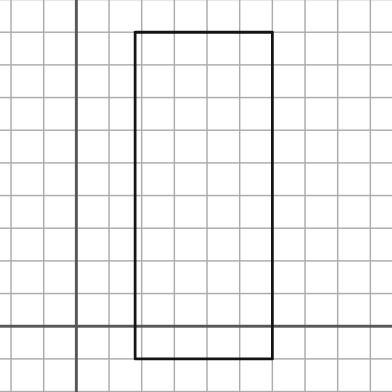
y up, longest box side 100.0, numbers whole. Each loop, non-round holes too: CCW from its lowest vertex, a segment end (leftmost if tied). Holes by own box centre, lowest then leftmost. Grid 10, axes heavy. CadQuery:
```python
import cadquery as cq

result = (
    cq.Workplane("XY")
    .moveTo(18.0, -10.0)
    .lineTo(60.0, -10.0)
    .lineTo(60.0, 90.0)
    .lineTo(18.0, 90.0)
    .close()
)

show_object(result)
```